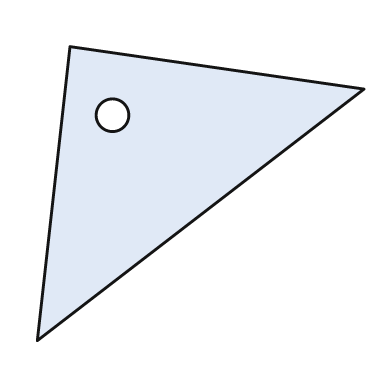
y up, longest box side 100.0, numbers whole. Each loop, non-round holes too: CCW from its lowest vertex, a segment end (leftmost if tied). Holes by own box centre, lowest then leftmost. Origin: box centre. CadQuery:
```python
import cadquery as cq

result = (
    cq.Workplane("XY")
    .moveTo(-50.0, -45.0)
    .lineTo(50.0, 32.0)
    .lineTo(-40.0, 45.0)
    .close()
    .moveTo(-27.0, 24.0)
    .circle(5.0)
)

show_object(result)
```